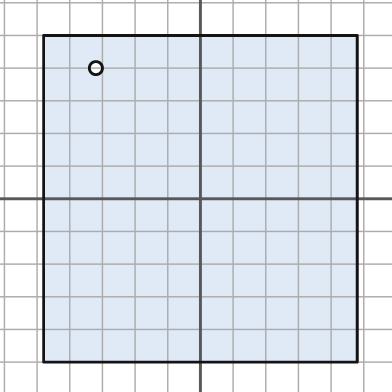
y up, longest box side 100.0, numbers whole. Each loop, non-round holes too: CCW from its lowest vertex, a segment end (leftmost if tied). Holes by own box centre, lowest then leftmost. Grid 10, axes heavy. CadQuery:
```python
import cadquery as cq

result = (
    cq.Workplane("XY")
    .moveTo(-48.0, -50.0)
    .lineTo(48.0, -50.0)
    .lineTo(48.0, 50.0)
    .lineTo(-48.0, 50.0)
    .close()
    .moveTo(-32.0, 40.0)
    .circle(2.0)
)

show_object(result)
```